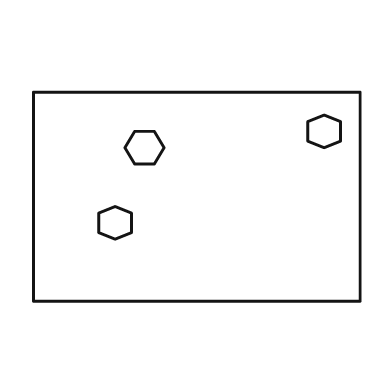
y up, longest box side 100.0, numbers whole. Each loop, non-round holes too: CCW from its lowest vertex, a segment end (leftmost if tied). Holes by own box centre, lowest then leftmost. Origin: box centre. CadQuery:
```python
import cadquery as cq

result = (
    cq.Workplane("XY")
    .moveTo(-50.0, -32.0)
    .lineTo(50.0, -32.0)
    .lineTo(50.0, 32.0)
    .lineTo(-50.0, 32.0)
    .close()
    .moveTo(-25.0, -13.0)
    .lineTo(-20.0, -11.0)
    .lineTo(-20.0, -5.0)
    .lineTo(-25.0, -3.0)
    .lineTo(-30.0, -5.0)
    .lineTo(-30.0, -11.0)
    .close()
    .moveTo(-19.0, 10.0)
    .lineTo(-13.0, 10.0)
    .lineTo(-10.0, 15.0)
    .lineTo(-13.0, 20.0)
    .lineTo(-19.0, 20.0)
    .lineTo(-22.0, 15.0)
    .close()
    .moveTo(39.0, 15.0)
    .lineTo(44.0, 17.0)
    .lineTo(44.0, 23.0)
    .lineTo(39.0, 25.0)
    .lineTo(34.0, 23.0)
    .lineTo(34.0, 17.0)
    .close()
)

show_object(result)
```